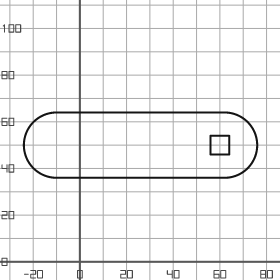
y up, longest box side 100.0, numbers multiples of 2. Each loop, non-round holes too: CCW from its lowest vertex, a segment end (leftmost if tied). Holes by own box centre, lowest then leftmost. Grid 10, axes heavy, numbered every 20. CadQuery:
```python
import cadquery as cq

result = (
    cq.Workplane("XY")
    .moveTo(-10.0, 36.0)
    .lineTo(62.0, 36.0)
    .threePointArc((76.0, 50.0), (62.0, 64.0))
    .lineTo(-10.0, 64.0)
    .threePointArc((-24.0, 50.0), (-10.0, 36.0))
    .close()
    .moveTo(56.0, 46.0)
    .lineTo(64.0, 46.0)
    .lineTo(64.0, 54.0)
    .lineTo(56.0, 54.0)
    .close()
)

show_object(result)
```